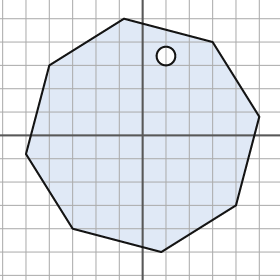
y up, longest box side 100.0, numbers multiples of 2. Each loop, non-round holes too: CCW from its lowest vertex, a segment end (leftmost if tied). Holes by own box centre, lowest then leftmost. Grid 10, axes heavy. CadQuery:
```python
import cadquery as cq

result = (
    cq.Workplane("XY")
    .moveTo(8.0, -50.0)
    .lineTo(40.0, -30.0)
    .lineTo(50.0, 8.0)
    .lineTo(30.0, 40.0)
    .lineTo(-8.0, 50.0)
    .lineTo(-40.0, 30.0)
    .lineTo(-50.0, -8.0)
    .lineTo(-30.0, -40.0)
    .close()
    .moveTo(10.0, 34.0)
    .circle(4.0)
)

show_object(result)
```